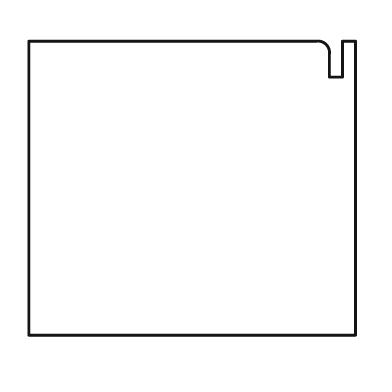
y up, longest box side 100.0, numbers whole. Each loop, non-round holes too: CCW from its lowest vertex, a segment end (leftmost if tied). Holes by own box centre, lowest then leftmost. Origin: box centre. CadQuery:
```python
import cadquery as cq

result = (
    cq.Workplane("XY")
    .moveTo(-50.0, -45.0)
    .lineTo(50.0, -45.0)
    .lineTo(50.0, 45.0)
    .lineTo(46.0, 45.0)
    .lineTo(46.0, 34.0)
    .lineTo(42.0, 34.0)
    .lineTo(42.0, 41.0)
    .threePointArc((41.0, 44.0), (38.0, 45.0))
    .lineTo(-50.0, 45.0)
    .close()
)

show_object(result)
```